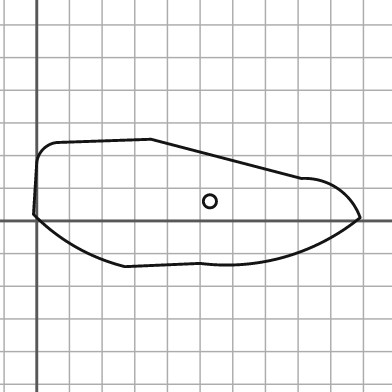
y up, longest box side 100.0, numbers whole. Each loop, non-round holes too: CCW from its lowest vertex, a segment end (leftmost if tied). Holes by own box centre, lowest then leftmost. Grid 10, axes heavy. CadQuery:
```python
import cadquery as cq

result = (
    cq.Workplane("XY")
    .moveTo(27.0, -14.0)
    .lineTo(50.0, -13.0)
    .threePointArc((76.0, -11.0), (99.0, 1.0))
    .threePointArc((92.0, 10.0), (81.0, 13.0))
    .lineTo(35.0, 25.0)
    .lineTo(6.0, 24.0)
    .threePointArc((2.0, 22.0), (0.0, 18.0))
    .lineTo(-1.0, 2.0)
    .threePointArc((12.0, -8.0), (27.0, -14.0))
    .close()
    .moveTo(53.0, 6.0)
    .circle(2.0)
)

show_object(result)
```